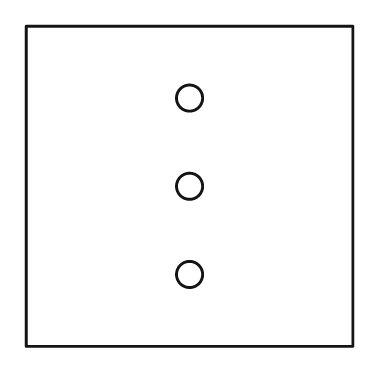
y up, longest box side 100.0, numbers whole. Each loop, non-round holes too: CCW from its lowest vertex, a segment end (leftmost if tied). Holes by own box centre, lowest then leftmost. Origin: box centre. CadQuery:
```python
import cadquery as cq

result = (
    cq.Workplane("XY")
    .moveTo(-50.0, -49.0)
    .lineTo(50.0, -49.0)
    .lineTo(50.0, 49.0)
    .lineTo(-50.0, 49.0)
    .close()
    .moveTo(0.0, -27.0)
    .circle(4.0)
    .moveTo(0.0, 0.0)
    .circle(4.0)
    .moveTo(0.0, 27.0)
    .circle(4.0)
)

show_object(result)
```